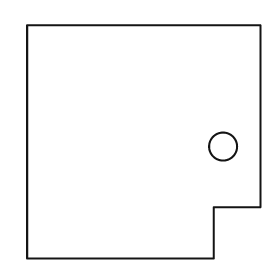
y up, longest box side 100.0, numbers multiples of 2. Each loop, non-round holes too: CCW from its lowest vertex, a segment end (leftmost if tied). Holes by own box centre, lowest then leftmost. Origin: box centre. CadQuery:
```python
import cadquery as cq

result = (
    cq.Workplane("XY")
    .moveTo(-50.0, -50.0)
    .lineTo(30.0, -50.0)
    .lineTo(30.0, -28.0)
    .lineTo(50.0, -28.0)
    .lineTo(50.0, 50.0)
    .lineTo(-50.0, 50.0)
    .close()
    .moveTo(34.0, -2.0)
    .circle(6.0)
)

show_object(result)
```